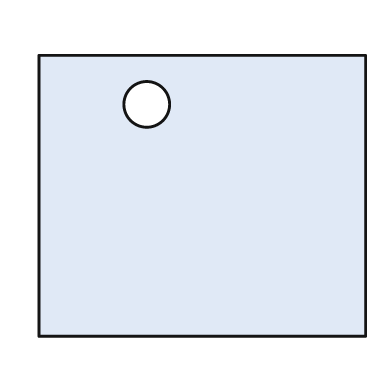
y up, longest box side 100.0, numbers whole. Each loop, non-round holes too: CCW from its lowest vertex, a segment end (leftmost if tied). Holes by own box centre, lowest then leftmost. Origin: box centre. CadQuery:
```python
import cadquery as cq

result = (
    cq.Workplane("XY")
    .moveTo(-50.0, -43.0)
    .lineTo(50.0, -43.0)
    .lineTo(50.0, 43.0)
    .lineTo(-50.0, 43.0)
    .close()
    .moveTo(-17.0, 28.0)
    .circle(7.0)
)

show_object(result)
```